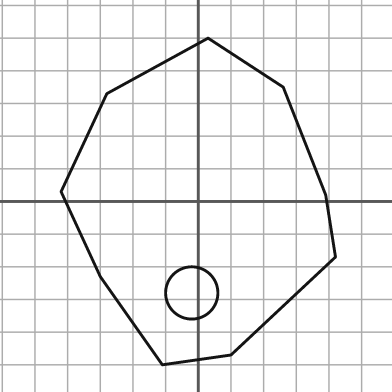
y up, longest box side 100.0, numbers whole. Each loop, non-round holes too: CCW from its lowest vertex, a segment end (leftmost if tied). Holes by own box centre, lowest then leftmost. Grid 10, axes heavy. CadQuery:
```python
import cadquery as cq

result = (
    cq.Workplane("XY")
    .moveTo(-11.0, -50.0)
    .lineTo(10.0, -47.0)
    .lineTo(42.0, -17.0)
    .lineTo(39.0, 2.0)
    .lineTo(26.0, 35.0)
    .lineTo(3.0, 50.0)
    .lineTo(-28.0, 33.0)
    .lineTo(-42.0, 3.0)
    .lineTo(-30.0, -23.0)
    .close()
    .moveTo(-2.0, -28.0)
    .circle(8.0)
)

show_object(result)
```